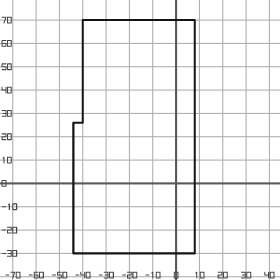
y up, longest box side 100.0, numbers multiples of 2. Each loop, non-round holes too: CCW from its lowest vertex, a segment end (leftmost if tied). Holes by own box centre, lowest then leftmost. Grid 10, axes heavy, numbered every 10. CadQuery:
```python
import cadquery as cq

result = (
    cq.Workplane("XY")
    .moveTo(-44.0, -30.0)
    .lineTo(8.0, -30.0)
    .lineTo(8.0, 70.0)
    .lineTo(-40.0, 70.0)
    .lineTo(-40.0, 26.0)
    .lineTo(-44.0, 26.0)
    .close()
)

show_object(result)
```